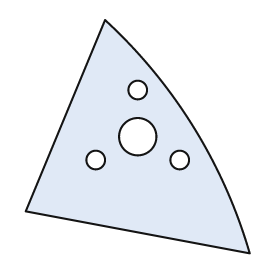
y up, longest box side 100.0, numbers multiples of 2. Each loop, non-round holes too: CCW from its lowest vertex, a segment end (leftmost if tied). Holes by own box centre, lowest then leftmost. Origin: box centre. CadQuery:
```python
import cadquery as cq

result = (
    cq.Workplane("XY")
    .moveTo(48.0, -50.0)
    .threePointArc((24.0, 4.0), (-14.0, 50.0))
    .lineTo(-48.0, -32.0)
    .close()
    .moveTo(-18.0, -10.0)
    .circle(4.0)
    .moveTo(18.0, -10.0)
    .circle(4.0)
    .moveTo(0.0, 0.0)
    .circle(8.0)
    .moveTo(0.0, 20.0)
    .circle(4.0)
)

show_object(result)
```